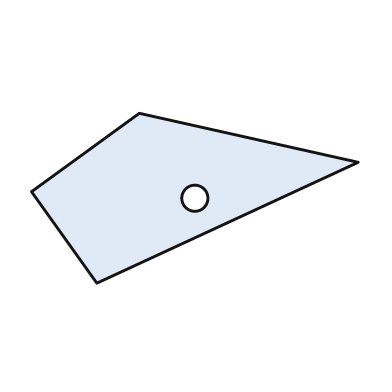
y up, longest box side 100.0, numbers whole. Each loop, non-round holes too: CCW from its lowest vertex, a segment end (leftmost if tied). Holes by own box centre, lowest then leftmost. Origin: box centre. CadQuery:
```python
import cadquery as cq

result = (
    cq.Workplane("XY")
    .moveTo(-30.0, -26.0)
    .lineTo(50.0, 11.0)
    .lineTo(-17.0, 26.0)
    .lineTo(-50.0, 2.0)
    .close()
    .moveTo(0.0, 0.0)
    .circle(4.0)
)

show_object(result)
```